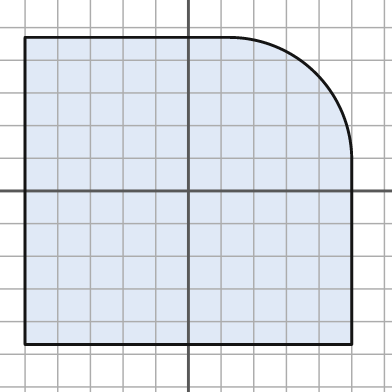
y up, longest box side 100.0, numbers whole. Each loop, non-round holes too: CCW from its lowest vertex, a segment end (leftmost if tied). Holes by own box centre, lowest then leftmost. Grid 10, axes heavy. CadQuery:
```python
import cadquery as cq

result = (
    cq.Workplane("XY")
    .moveTo(-50.0, -47.0)
    .lineTo(50.0, -47.0)
    .lineTo(50.0, 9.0)
    .threePointArc((39.0, 36.0), (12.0, 47.0))
    .lineTo(-50.0, 47.0)
    .close()
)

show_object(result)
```